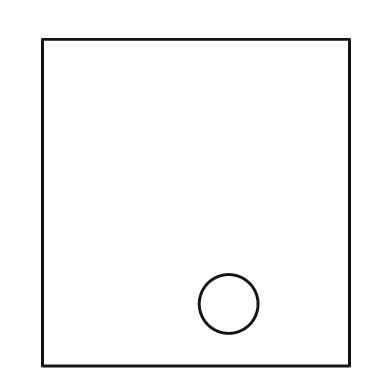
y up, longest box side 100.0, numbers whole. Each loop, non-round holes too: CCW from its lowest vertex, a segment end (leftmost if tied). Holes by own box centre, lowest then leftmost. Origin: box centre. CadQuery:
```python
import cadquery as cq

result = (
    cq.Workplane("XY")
    .moveTo(-47.0, -50.0)
    .lineTo(47.0, -50.0)
    .lineTo(47.0, 50.0)
    .lineTo(-47.0, 50.0)
    .close()
    .moveTo(10.0, -31.0)
    .circle(9.0)
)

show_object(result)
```